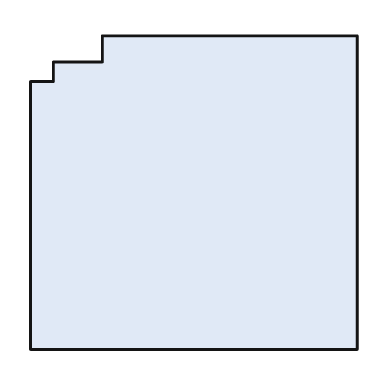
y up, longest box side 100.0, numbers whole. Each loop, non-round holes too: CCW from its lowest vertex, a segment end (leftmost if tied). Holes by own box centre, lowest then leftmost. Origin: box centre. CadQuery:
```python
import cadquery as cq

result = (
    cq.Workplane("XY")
    .moveTo(-50.0, -48.0)
    .lineTo(50.0, -48.0)
    .lineTo(50.0, 48.0)
    .lineTo(-28.0, 48.0)
    .lineTo(-28.0, 40.0)
    .lineTo(-43.0, 40.0)
    .lineTo(-43.0, 34.0)
    .lineTo(-50.0, 34.0)
    .close()
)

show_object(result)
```